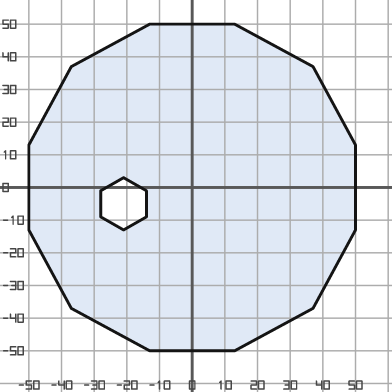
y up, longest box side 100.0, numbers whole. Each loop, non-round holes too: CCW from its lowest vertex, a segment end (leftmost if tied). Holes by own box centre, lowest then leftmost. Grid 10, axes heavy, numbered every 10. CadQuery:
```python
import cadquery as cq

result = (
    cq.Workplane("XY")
    .moveTo(-13.0, -50.0)
    .lineTo(13.0, -50.0)
    .lineTo(37.0, -37.0)
    .lineTo(50.0, -13.0)
    .lineTo(50.0, 13.0)
    .lineTo(37.0, 37.0)
    .lineTo(13.0, 50.0)
    .lineTo(-13.0, 50.0)
    .lineTo(-37.0, 37.0)
    .lineTo(-50.0, 13.0)
    .lineTo(-50.0, -13.0)
    .lineTo(-37.0, -37.0)
    .close()
    .moveTo(-21.0, -13.0)
    .lineTo(-14.0, -9.0)
    .lineTo(-14.0, -1.0)
    .lineTo(-21.0, 3.0)
    .lineTo(-28.0, -1.0)
    .lineTo(-28.0, -9.0)
    .close()
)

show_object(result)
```